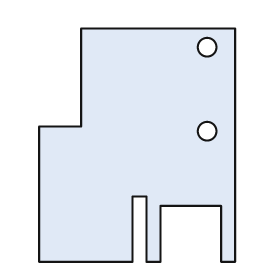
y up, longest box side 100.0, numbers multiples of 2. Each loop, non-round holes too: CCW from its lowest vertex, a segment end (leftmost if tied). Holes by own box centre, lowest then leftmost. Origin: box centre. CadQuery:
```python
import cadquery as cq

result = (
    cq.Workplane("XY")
    .moveTo(-42.0, -50.0)
    .lineTo(-2.0, -50.0)
    .lineTo(-2.0, -22.0)
    .lineTo(4.0, -22.0)
    .lineTo(4.0, -50.0)
    .lineTo(10.0, -50.0)
    .lineTo(10.0, -26.0)
    .lineTo(36.0, -26.0)
    .lineTo(36.0, -50.0)
    .lineTo(42.0, -50.0)
    .lineTo(42.0, 50.0)
    .lineTo(-24.0, 50.0)
    .lineTo(-24.0, 8.0)
    .lineTo(-42.0, 8.0)
    .close()
    .moveTo(30.0, 6.0)
    .circle(4.0)
    .moveTo(30.0, 42.0)
    .circle(4.0)
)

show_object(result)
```